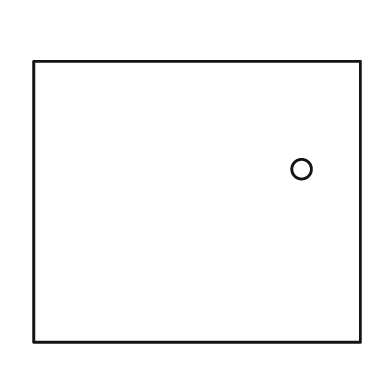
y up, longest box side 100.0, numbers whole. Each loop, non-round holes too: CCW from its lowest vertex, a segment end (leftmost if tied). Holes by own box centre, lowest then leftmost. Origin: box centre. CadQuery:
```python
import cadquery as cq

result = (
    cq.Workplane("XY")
    .moveTo(-50.0, -43.0)
    .lineTo(50.0, -43.0)
    .lineTo(50.0, 43.0)
    .lineTo(-50.0, 43.0)
    .close()
    .moveTo(32.0, 10.0)
    .circle(3.0)
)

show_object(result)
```